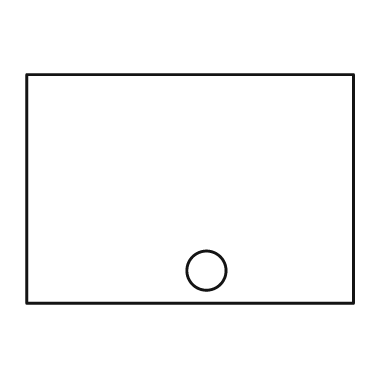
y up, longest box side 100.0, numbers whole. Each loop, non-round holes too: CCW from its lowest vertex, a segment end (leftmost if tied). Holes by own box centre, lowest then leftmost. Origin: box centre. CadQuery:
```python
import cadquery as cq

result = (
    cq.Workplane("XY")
    .moveTo(-50.0, -35.0)
    .lineTo(50.0, -35.0)
    .lineTo(50.0, 35.0)
    .lineTo(-50.0, 35.0)
    .close()
    .moveTo(5.0, -25.0)
    .circle(6.0)
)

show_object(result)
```